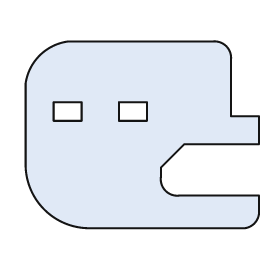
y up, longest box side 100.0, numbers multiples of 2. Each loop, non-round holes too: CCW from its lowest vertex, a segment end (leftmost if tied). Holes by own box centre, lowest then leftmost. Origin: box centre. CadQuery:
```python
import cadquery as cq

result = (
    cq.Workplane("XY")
    .moveTo(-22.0, -40.0)
    .lineTo(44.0, -40.0)
    .threePointArc((48.0, -38.0), (50.0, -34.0))
    .lineTo(50.0, -26.0)
    .lineTo(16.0, -26.0)
    .threePointArc((10.0, -24.0), (8.0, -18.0))
    .lineTo(8.0, -14.0)
    .lineTo(18.0, -4.0)
    .lineTo(50.0, -4.0)
    .lineTo(50.0, 8.0)
    .lineTo(38.0, 8.0)
    .lineTo(38.0, 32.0)
    .threePointArc((36.0, 38.0), (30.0, 40.0))
    .lineTo(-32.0, 40.0)
    .threePointArc((-44.0, 34.0), (-50.0, 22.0))
    .lineTo(-50.0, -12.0)
    .threePointArc((-42.0, -32.0), (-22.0, -40.0))
    .close()
    .moveTo(-38.0, 6.0)
    .lineTo(-26.0, 6.0)
    .lineTo(-26.0, 14.0)
    .lineTo(-38.0, 14.0)
    .close()
    .moveTo(-10.0, 6.0)
    .lineTo(2.0, 6.0)
    .lineTo(2.0, 14.0)
    .lineTo(-10.0, 14.0)
    .close()
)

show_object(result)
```